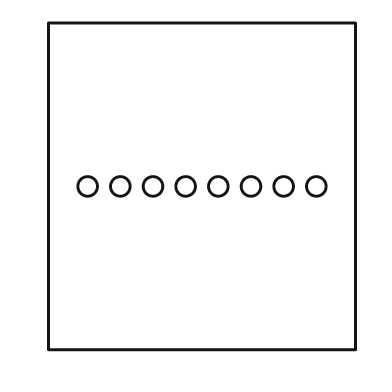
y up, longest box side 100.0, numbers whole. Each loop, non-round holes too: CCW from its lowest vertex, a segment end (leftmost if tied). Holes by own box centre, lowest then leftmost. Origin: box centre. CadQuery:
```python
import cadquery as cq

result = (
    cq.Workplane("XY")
    .moveTo(-47.0, -50.0)
    .lineTo(47.0, -50.0)
    .lineTo(47.0, 50.0)
    .lineTo(-47.0, 50.0)
    .close()
    .moveTo(-35.0, 0.0)
    .circle(3.0)
    .moveTo(-25.0, 0.0)
    .circle(3.0)
    .moveTo(-15.0, 0.0)
    .circle(3.0)
    .moveTo(-5.0, 0.0)
    .circle(3.0)
    .moveTo(5.0, 0.0)
    .circle(3.0)
    .moveTo(15.0, 0.0)
    .circle(3.0)
    .moveTo(25.0, 0.0)
    .circle(3.0)
    .moveTo(35.0, 0.0)
    .circle(3.0)
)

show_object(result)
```